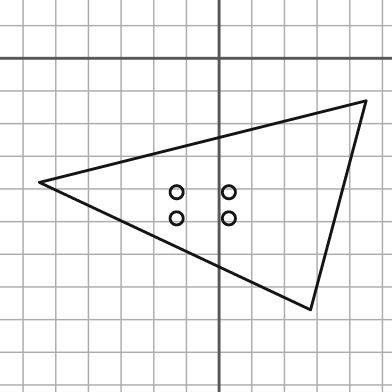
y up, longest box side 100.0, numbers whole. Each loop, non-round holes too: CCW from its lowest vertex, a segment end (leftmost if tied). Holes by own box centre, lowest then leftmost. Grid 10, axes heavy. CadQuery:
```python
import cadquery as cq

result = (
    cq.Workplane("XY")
    .moveTo(28.0, -77.0)
    .lineTo(45.0, -13.0)
    .lineTo(-55.0, -38.0)
    .close()
    .moveTo(-13.0, -49.0)
    .circle(2.0)
    .moveTo(3.0, -49.0)
    .circle(2.0)
    .moveTo(-13.0, -41.0)
    .circle(2.0)
    .moveTo(3.0, -41.0)
    .circle(2.0)
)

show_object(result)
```